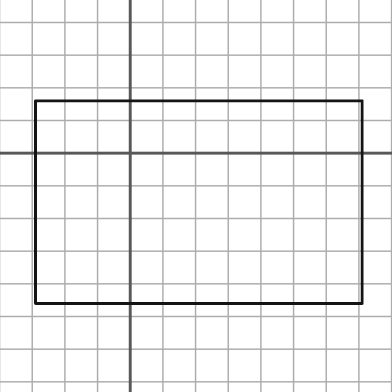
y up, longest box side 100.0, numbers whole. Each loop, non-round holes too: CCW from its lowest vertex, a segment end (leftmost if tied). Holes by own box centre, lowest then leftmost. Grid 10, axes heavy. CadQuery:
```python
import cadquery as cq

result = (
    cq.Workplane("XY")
    .moveTo(-29.0, -46.0)
    .lineTo(71.0, -46.0)
    .lineTo(71.0, 16.0)
    .lineTo(-29.0, 16.0)
    .close()
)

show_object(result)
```